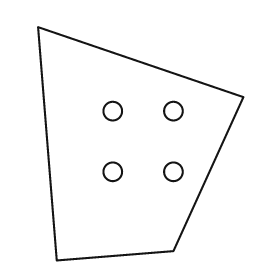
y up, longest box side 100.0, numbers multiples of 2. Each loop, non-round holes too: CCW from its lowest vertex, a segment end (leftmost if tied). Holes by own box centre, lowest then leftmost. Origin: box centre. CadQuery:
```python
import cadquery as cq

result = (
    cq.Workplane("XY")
    .moveTo(-36.0, -50.0)
    .lineTo(14.0, -46.0)
    .lineTo(44.0, 20.0)
    .lineTo(-44.0, 50.0)
    .close()
    .moveTo(-12.0, -12.0)
    .circle(4.0)
    .moveTo(14.0, -12.0)
    .circle(4.0)
    .moveTo(-12.0, 14.0)
    .circle(4.0)
    .moveTo(14.0, 14.0)
    .circle(4.0)
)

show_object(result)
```